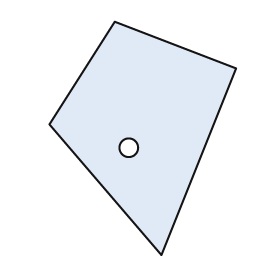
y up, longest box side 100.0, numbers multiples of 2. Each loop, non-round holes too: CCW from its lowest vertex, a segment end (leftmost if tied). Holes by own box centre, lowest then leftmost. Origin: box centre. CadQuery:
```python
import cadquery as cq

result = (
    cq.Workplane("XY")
    .moveTo(8.0, -50.0)
    .lineTo(40.0, 30.0)
    .lineTo(-12.0, 50.0)
    .lineTo(-40.0, 6.0)
    .close()
    .moveTo(-6.0, -4.0)
    .circle(4.0)
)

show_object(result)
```